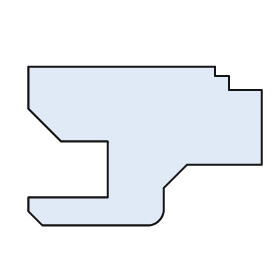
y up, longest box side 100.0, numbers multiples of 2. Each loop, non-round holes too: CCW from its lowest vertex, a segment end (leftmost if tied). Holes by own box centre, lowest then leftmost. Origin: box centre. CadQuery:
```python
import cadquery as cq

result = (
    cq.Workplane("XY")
    .moveTo(-44.0, -34.0)
    .lineTo(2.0, -34.0)
    .threePointArc((6.0, -32.0), (8.0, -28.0))
    .lineTo(8.0, -18.0)
    .lineTo(18.0, -8.0)
    .lineTo(50.0, -8.0)
    .lineTo(50.0, 24.0)
    .lineTo(36.0, 24.0)
    .lineTo(36.0, 30.0)
    .lineTo(30.0, 30.0)
    .lineTo(30.0, 34.0)
    .lineTo(-50.0, 34.0)
    .lineTo(-50.0, 16.0)
    .lineTo(-36.0, 2.0)
    .lineTo(-16.0, 2.0)
    .lineTo(-16.0, -22.0)
    .lineTo(-50.0, -22.0)
    .lineTo(-50.0, -28.0)
    .close()
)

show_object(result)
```